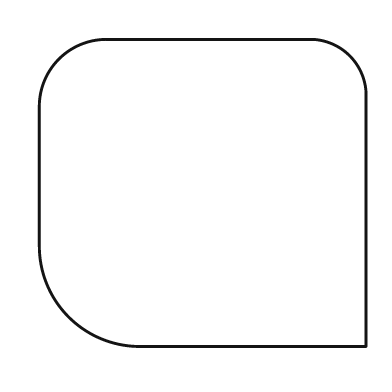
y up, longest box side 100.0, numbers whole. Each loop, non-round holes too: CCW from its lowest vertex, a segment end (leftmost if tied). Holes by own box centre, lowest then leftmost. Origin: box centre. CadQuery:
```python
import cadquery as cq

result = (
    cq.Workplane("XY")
    .moveTo(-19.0, -47.0)
    .lineTo(50.0, -47.0)
    .lineTo(50.0, 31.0)
    .threePointArc((45.0, 42.0), (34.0, 47.0))
    .lineTo(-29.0, 47.0)
    .threePointArc((-44.0, 41.0), (-50.0, 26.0))
    .lineTo(-50.0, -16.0)
    .threePointArc((-41.0, -38.0), (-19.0, -47.0))
    .close()
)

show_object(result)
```